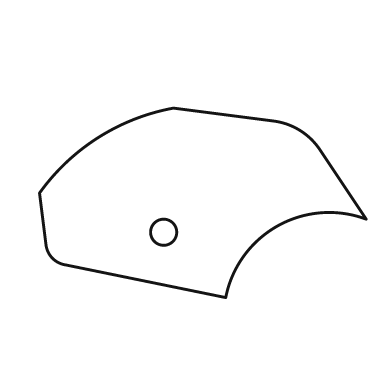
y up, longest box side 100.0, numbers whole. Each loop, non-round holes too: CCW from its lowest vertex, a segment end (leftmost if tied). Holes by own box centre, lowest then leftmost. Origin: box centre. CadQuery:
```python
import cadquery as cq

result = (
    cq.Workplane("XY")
    .moveTo(7.0, -29.0)
    .threePointArc((23.0, -7.0), (50.0, -5.0))
    .lineTo(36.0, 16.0)
    .threePointArc((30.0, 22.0), (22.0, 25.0))
    .lineTo(-9.0, 29.0)
    .threePointArc((-32.0, 20.0), (-50.0, 3.0))
    .lineTo(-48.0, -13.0)
    .threePointArc((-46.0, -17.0), (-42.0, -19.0))
    .close()
    .moveTo(-12.0, -9.0)
    .circle(4.0)
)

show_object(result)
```